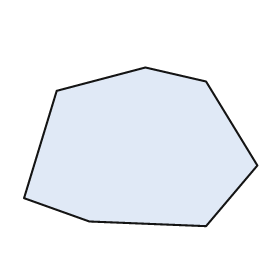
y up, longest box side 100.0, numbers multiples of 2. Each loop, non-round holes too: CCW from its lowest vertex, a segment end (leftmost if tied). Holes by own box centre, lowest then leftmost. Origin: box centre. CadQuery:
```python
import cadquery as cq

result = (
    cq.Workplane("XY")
    .moveTo(28.0, -34.0)
    .lineTo(50.0, -8.0)
    .lineTo(28.0, 28.0)
    .lineTo(2.0, 34.0)
    .lineTo(-36.0, 24.0)
    .lineTo(-50.0, -22.0)
    .lineTo(-22.0, -32.0)
    .close()
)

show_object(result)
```